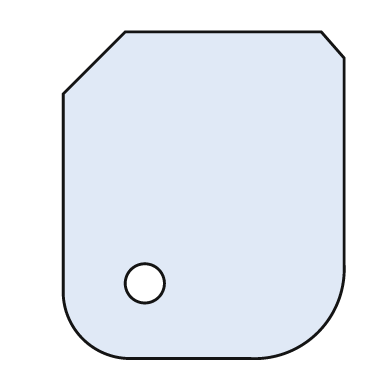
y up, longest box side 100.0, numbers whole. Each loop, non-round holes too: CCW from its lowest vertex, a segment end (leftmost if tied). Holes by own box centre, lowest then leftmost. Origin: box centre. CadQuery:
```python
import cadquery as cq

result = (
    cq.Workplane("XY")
    .moveTo(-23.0, -50.0)
    .lineTo(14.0, -50.0)
    .threePointArc((35.0, -42.0), (43.0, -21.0))
    .lineTo(43.0, 42.0)
    .lineTo(36.0, 50.0)
    .lineTo(-24.0, 50.0)
    .lineTo(-43.0, 31.0)
    .lineTo(-43.0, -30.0)
    .threePointArc((-37.0, -44.0), (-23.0, -50.0))
    .close()
    .moveTo(-18.0, -27.0)
    .circle(6.0)
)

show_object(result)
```